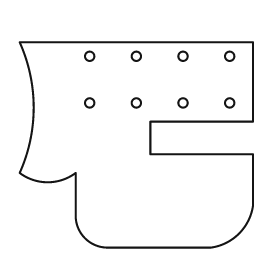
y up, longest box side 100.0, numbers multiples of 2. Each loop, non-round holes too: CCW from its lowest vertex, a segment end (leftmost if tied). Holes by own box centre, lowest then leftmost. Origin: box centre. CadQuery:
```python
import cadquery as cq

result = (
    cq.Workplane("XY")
    .moveTo(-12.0, -44.0)
    .lineTo(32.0, -44.0)
    .threePointArc((44.0, -38.0), (50.0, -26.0))
    .lineTo(50.0, -4.0)
    .lineTo(6.0, -4.0)
    .lineTo(6.0, 10.0)
    .lineTo(50.0, 10.0)
    .lineTo(50.0, 44.0)
    .lineTo(-50.0, 44.0)
    .threePointArc((-44.0, 16.0), (-50.0, -12.0))
    .threePointArc((-38.0, -16.0), (-26.0, -12.0))
    .lineTo(-26.0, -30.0)
    .threePointArc((-22.0, -40.0), (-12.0, -44.0))
    .close()
    .moveTo(-20.0, 18.0)
    .circle(2.0)
    .moveTo(0.0, 18.0)
    .circle(2.0)
    .moveTo(20.0, 18.0)
    .circle(2.0)
    .moveTo(40.0, 18.0)
    .circle(2.0)
    .moveTo(-20.0, 38.0)
    .circle(2.0)
    .moveTo(0.0, 38.0)
    .circle(2.0)
    .moveTo(20.0, 38.0)
    .circle(2.0)
    .moveTo(40.0, 38.0)
    .circle(2.0)
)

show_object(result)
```